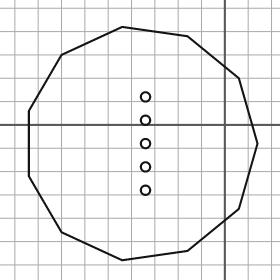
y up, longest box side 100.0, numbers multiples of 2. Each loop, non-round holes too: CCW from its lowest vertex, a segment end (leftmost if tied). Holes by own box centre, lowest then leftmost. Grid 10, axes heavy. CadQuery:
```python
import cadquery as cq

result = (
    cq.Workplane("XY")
    .moveTo(-44.0, -58.0)
    .lineTo(-16.0, -54.0)
    .lineTo(6.0, -36.0)
    .lineTo(14.0, -8.0)
    .lineTo(6.0, 20.0)
    .lineTo(-16.0, 38.0)
    .lineTo(-44.0, 42.0)
    .lineTo(-70.0, 30.0)
    .lineTo(-84.0, 6.0)
    .lineTo(-84.0, -22.0)
    .lineTo(-70.0, -46.0)
    .close()
    .moveTo(-34.0, -28.0)
    .circle(2.0)
    .moveTo(-34.0, -18.0)
    .circle(2.0)
    .moveTo(-34.0, -8.0)
    .circle(2.0)
    .moveTo(-34.0, 2.0)
    .circle(2.0)
    .moveTo(-34.0, 12.0)
    .circle(2.0)
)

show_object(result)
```